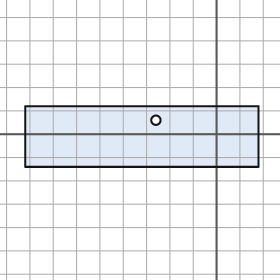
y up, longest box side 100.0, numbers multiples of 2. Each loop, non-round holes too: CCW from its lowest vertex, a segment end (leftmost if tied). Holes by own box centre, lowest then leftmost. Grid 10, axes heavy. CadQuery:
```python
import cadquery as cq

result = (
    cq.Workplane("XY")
    .moveTo(-82.0, -14.0)
    .lineTo(18.0, -14.0)
    .lineTo(18.0, 12.0)
    .lineTo(-82.0, 12.0)
    .close()
    .moveTo(-26.0, 6.0)
    .circle(2.0)
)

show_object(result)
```